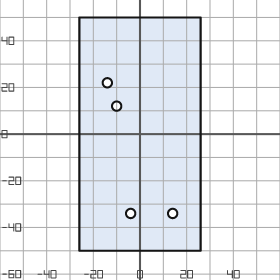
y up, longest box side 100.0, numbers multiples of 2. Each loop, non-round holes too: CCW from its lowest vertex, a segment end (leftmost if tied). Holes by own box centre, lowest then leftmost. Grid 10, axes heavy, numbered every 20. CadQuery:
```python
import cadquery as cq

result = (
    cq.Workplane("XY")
    .moveTo(-26.0, -50.0)
    .lineTo(26.0, -50.0)
    .lineTo(26.0, 50.0)
    .lineTo(-26.0, 50.0)
    .close()
    .moveTo(-4.0, -34.0)
    .circle(2.0)
    .moveTo(14.0, -34.0)
    .circle(2.0)
    .moveTo(-10.0, 12.0)
    .circle(2.0)
    .moveTo(-14.0, 22.0)
    .circle(2.0)
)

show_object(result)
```